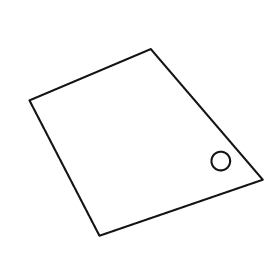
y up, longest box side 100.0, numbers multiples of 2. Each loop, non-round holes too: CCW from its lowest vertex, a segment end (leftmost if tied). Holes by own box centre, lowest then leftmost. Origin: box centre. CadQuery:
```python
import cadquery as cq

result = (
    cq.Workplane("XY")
    .moveTo(-20.0, -40.0)
    .lineTo(50.0, -16.0)
    .lineTo(2.0, 40.0)
    .lineTo(-50.0, 18.0)
    .close()
    .moveTo(32.0, -8.0)
    .circle(4.0)
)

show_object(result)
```